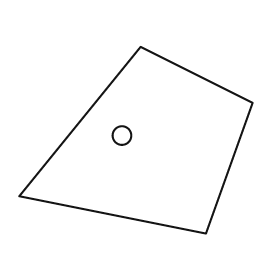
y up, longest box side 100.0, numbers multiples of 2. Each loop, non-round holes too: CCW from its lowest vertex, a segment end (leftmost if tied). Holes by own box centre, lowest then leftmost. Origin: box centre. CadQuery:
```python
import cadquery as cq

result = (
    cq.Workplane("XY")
    .moveTo(30.0, -40.0)
    .lineTo(50.0, 16.0)
    .lineTo(2.0, 40.0)
    .lineTo(-50.0, -24.0)
    .close()
    .moveTo(-6.0, 2.0)
    .circle(4.0)
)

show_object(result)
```